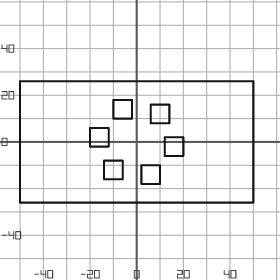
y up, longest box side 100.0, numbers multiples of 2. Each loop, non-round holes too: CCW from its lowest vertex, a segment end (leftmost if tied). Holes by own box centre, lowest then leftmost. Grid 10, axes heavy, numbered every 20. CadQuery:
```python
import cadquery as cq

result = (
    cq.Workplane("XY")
    .moveTo(-50.0, -26.0)
    .lineTo(50.0, -26.0)
    .lineTo(50.0, 26.0)
    .lineTo(-50.0, 26.0)
    .close()
    .moveTo(2.0, -18.0)
    .lineTo(10.0, -18.0)
    .lineTo(10.0, -10.0)
    .lineTo(2.0, -10.0)
    .close()
    .moveTo(-14.0, -16.0)
    .lineTo(-6.0, -16.0)
    .lineTo(-6.0, -8.0)
    .lineTo(-14.0, -8.0)
    .close()
    .moveTo(12.0, -6.0)
    .lineTo(20.0, -6.0)
    .lineTo(20.0, 2.0)
    .lineTo(12.0, 2.0)
    .close()
    .moveTo(-20.0, -2.0)
    .lineTo(-12.0, -2.0)
    .lineTo(-12.0, 6.0)
    .lineTo(-20.0, 6.0)
    .close()
    .moveTo(6.0, 8.0)
    .lineTo(14.0, 8.0)
    .lineTo(14.0, 16.0)
    .lineTo(6.0, 16.0)
    .close()
    .moveTo(-10.0, 10.0)
    .lineTo(-2.0, 10.0)
    .lineTo(-2.0, 18.0)
    .lineTo(-10.0, 18.0)
    .close()
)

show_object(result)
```